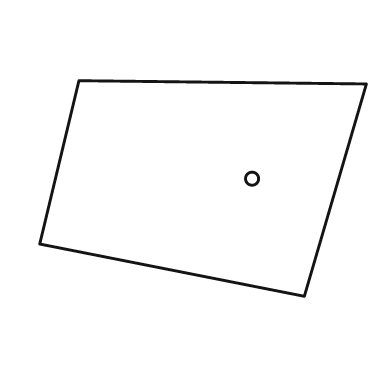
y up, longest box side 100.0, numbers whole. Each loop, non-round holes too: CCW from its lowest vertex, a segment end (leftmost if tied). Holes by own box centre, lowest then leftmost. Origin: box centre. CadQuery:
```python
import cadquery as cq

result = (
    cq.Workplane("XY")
    .moveTo(31.0, -33.0)
    .lineTo(50.0, 32.0)
    .lineTo(-38.0, 33.0)
    .lineTo(-50.0, -17.0)
    .close()
    .moveTo(15.0, 3.0)
    .circle(2.0)
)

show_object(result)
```